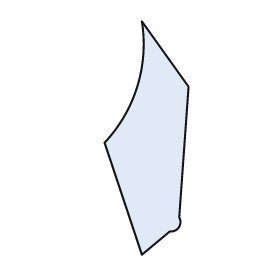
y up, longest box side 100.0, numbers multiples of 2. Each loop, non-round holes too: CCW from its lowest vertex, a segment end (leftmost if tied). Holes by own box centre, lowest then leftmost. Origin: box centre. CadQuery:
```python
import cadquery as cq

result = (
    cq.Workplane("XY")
    .moveTo(-2.0, -50.0)
    .lineTo(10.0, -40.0)
    .threePointArc((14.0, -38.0), (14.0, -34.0))
    .lineTo(18.0, 22.0)
    .lineTo(-2.0, 50.0)
    .threePointArc((-4.0, 22.0), (-18.0, -2.0))
    .close()
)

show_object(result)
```